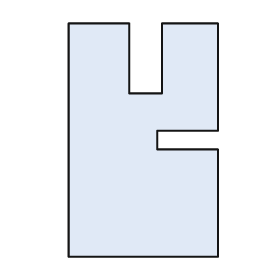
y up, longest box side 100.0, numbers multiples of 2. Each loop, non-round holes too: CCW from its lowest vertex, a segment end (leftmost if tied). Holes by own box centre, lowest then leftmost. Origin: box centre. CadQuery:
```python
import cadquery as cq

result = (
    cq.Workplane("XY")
    .moveTo(-32.0, -50.0)
    .lineTo(32.0, -50.0)
    .lineTo(32.0, -4.0)
    .lineTo(6.0, -4.0)
    .lineTo(6.0, 4.0)
    .lineTo(32.0, 4.0)
    .lineTo(32.0, 50.0)
    .lineTo(8.0, 50.0)
    .lineTo(8.0, 20.0)
    .lineTo(-6.0, 20.0)
    .lineTo(-6.0, 50.0)
    .lineTo(-32.0, 50.0)
    .close()
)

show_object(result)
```